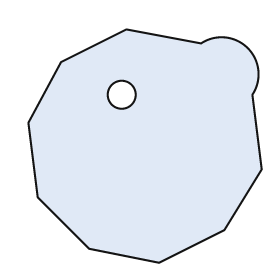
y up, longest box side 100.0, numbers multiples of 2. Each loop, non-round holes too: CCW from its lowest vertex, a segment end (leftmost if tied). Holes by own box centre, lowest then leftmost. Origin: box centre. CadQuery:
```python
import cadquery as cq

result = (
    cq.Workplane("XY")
    .moveTo(6.0, -50.0)
    .lineTo(34.0, -36.0)
    .lineTo(50.0, -10.0)
    .lineTo(46.0, 22.0)
    .threePointArc((44.0, 42.0), (24.0, 44.0))
    .lineTo(-8.0, 50.0)
    .lineTo(-36.0, 36.0)
    .lineTo(-50.0, 10.0)
    .lineTo(-46.0, -22.0)
    .lineTo(-24.0, -44.0)
    .close()
    .moveTo(-10.0, 22.0)
    .circle(6.0)
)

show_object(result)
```